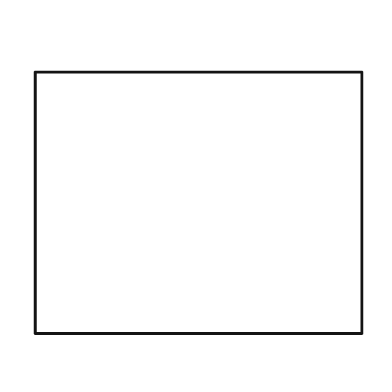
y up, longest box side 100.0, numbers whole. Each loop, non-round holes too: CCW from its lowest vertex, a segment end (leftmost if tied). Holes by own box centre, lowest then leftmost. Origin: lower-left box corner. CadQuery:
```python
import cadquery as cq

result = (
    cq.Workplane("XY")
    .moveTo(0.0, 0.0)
    .lineTo(100.0, 0.0)
    .lineTo(100.0, 80.0)
    .lineTo(0.0, 80.0)
    .close()
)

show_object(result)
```